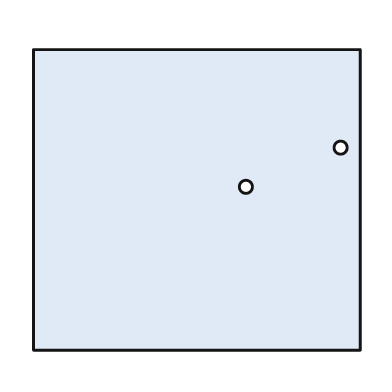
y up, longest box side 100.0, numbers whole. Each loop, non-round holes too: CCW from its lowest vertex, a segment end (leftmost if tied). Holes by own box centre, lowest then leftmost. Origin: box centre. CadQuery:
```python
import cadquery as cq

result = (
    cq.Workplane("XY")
    .moveTo(-50.0, -46.0)
    .lineTo(50.0, -46.0)
    .lineTo(50.0, 46.0)
    .lineTo(-50.0, 46.0)
    .close()
    .moveTo(15.0, 4.0)
    .circle(2.0)
    .moveTo(44.0, 16.0)
    .circle(2.0)
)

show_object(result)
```